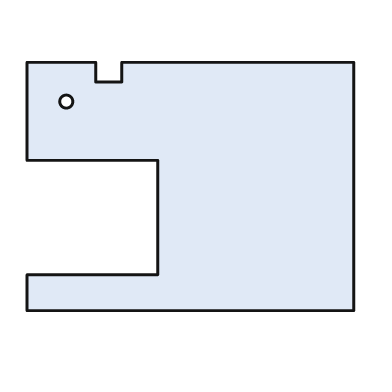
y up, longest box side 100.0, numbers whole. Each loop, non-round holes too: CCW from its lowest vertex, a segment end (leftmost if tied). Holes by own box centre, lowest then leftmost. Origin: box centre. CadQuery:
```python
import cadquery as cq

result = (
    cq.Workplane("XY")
    .moveTo(-50.0, -38.0)
    .lineTo(50.0, -38.0)
    .lineTo(50.0, 38.0)
    .lineTo(-21.0, 38.0)
    .lineTo(-21.0, 32.0)
    .lineTo(-29.0, 32.0)
    .lineTo(-29.0, 38.0)
    .lineTo(-50.0, 38.0)
    .lineTo(-50.0, 8.0)
    .lineTo(-10.0, 8.0)
    .lineTo(-10.0, -27.0)
    .lineTo(-50.0, -27.0)
    .close()
    .moveTo(-38.0, 26.0)
    .circle(2.0)
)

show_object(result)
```